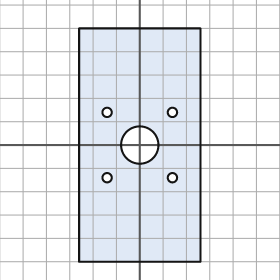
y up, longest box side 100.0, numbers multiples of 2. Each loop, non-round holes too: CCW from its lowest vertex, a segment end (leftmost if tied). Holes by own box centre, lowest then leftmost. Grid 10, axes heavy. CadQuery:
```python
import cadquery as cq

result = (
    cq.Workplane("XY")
    .moveTo(-26.0, -50.0)
    .lineTo(26.0, -50.0)
    .lineTo(26.0, 50.0)
    .lineTo(-26.0, 50.0)
    .close()
    .moveTo(-14.0, -14.0)
    .circle(2.0)
    .moveTo(14.0, -14.0)
    .circle(2.0)
    .moveTo(0.0, 0.0)
    .circle(8.0)
    .moveTo(-14.0, 14.0)
    .circle(2.0)
    .moveTo(14.0, 14.0)
    .circle(2.0)
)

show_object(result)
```